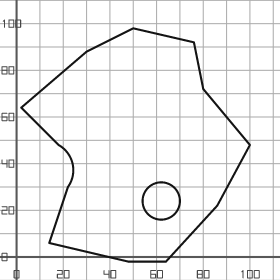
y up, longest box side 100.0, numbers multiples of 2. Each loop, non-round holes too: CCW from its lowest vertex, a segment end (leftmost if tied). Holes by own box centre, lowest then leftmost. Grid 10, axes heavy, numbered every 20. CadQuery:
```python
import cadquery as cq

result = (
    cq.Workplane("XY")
    .moveTo(48.0, -2.0)
    .lineTo(64.0, -2.0)
    .lineTo(86.0, 22.0)
    .lineTo(100.0, 48.0)
    .lineTo(80.0, 72.0)
    .lineTo(76.0, 92.0)
    .lineTo(50.0, 98.0)
    .lineTo(30.0, 88.0)
    .lineTo(2.0, 64.0)
    .lineTo(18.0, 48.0)
    .threePointArc((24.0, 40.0), (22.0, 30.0))
    .lineTo(14.0, 6.0)
    .close()
    .moveTo(62.0, 24.0)
    .circle(8.0)
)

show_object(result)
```